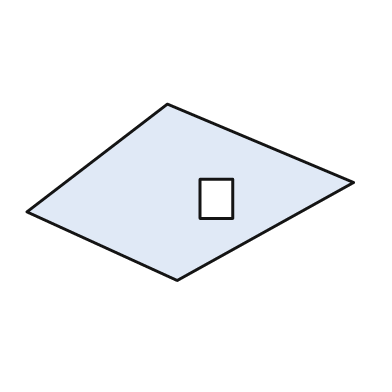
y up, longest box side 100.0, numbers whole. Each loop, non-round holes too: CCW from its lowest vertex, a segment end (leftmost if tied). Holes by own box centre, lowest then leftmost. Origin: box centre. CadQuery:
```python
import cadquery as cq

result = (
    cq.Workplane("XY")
    .moveTo(-4.0, -27.0)
    .lineTo(50.0, 3.0)
    .lineTo(-7.0, 27.0)
    .lineTo(-50.0, -6.0)
    .close()
    .moveTo(3.0, -8.0)
    .lineTo(13.0, -8.0)
    .lineTo(13.0, 4.0)
    .lineTo(3.0, 4.0)
    .close()
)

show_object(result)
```